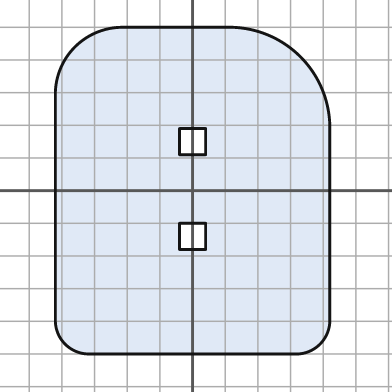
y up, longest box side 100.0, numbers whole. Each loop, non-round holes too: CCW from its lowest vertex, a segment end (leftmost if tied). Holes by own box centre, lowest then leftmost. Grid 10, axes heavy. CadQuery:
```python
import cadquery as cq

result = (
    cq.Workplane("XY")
    .moveTo(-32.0, -50.0)
    .lineTo(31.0, -50.0)
    .threePointArc((39.0, -47.0), (42.0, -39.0))
    .lineTo(42.0, 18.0)
    .threePointArc((33.0, 41.0), (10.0, 50.0))
    .lineTo(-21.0, 50.0)
    .threePointArc((-36.0, 44.0), (-42.0, 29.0))
    .lineTo(-42.0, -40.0)
    .threePointArc((-39.0, -47.0), (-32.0, -50.0))
    .close()
    .moveTo(-4.0, -18.0)
    .lineTo(4.0, -18.0)
    .lineTo(4.0, -10.0)
    .lineTo(-4.0, -10.0)
    .close()
    .moveTo(-4.0, 11.0)
    .lineTo(4.0, 11.0)
    .lineTo(4.0, 19.0)
    .lineTo(-4.0, 19.0)
    .close()
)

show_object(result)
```